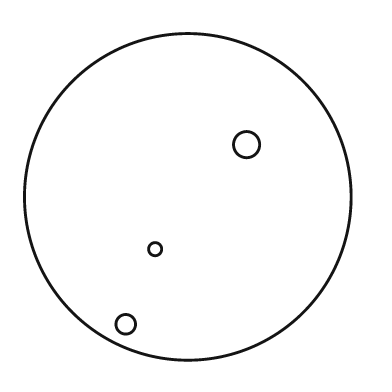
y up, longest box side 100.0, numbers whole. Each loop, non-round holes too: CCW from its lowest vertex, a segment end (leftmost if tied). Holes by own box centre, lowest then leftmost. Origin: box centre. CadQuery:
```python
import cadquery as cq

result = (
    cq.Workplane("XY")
    .moveTo(0.0, 0.0)
    .circle(50.0)
    .moveTo(-19.0, -39.0)
    .circle(3.0)
    .moveTo(-10.0, -16.0)
    .circle(2.0)
    .moveTo(18.0, 16.0)
    .circle(4.0)
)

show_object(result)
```